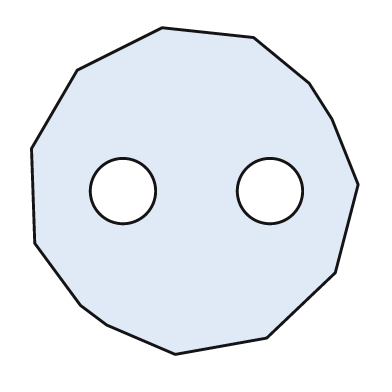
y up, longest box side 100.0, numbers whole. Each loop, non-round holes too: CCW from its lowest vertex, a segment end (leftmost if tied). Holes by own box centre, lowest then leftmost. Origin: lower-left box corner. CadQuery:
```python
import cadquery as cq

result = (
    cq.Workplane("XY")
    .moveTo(44.0, 0.0)
    .lineTo(72.0, 5.0)
    .lineTo(93.0, 25.0)
    .lineTo(100.0, 52.0)
    .lineTo(92.0, 72.0)
    .lineTo(85.0, 83.0)
    .lineTo(68.0, 97.0)
    .lineTo(40.0, 100.0)
    .lineTo(14.0, 87.0)
    .lineTo(0.0, 63.0)
    .lineTo(1.0, 34.0)
    .lineTo(15.0, 15.0)
    .lineTo(23.0, 9.0)
    .close()
    .moveTo(28.0, 50.0)
    .circle(10.0)
    .moveTo(73.0, 50.0)
    .circle(10.0)
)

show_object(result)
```